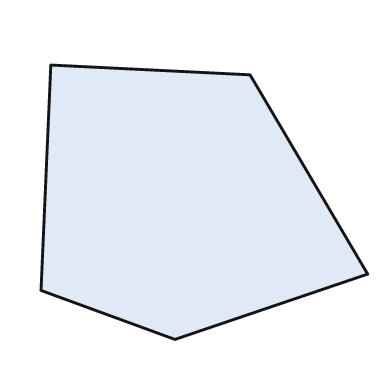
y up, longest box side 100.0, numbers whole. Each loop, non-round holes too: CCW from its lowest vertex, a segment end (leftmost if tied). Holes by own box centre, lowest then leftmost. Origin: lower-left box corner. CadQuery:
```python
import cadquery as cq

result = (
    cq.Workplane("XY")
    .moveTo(41.0, 0.0)
    .lineTo(100.0, 20.0)
    .lineTo(64.0, 81.0)
    .lineTo(3.0, 84.0)
    .lineTo(0.0, 15.0)
    .close()
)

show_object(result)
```